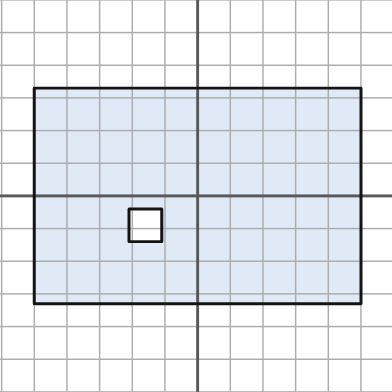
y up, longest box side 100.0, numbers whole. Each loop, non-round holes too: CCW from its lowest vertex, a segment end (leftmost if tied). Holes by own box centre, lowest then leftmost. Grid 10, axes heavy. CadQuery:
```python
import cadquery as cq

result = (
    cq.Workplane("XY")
    .moveTo(-50.0, -33.0)
    .lineTo(50.0, -33.0)
    .lineTo(50.0, 33.0)
    .lineTo(-50.0, 33.0)
    .close()
    .moveTo(-21.0, -14.0)
    .lineTo(-11.0, -14.0)
    .lineTo(-11.0, -4.0)
    .lineTo(-21.0, -4.0)
    .close()
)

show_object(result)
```